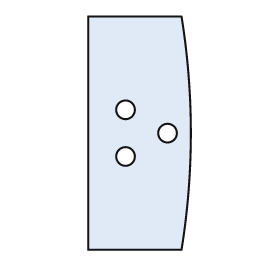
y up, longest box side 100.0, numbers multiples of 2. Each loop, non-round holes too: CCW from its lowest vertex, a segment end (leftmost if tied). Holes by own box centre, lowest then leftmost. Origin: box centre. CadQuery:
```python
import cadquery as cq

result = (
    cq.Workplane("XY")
    .moveTo(-22.0, -50.0)
    .lineTo(18.0, -50.0)
    .threePointArc((22.0, 0.0), (18.0, 50.0))
    .lineTo(-22.0, 50.0)
    .close()
    .moveTo(-6.0, -10.0)
    .circle(4.0)
    .moveTo(12.0, 0.0)
    .circle(4.0)
    .moveTo(-6.0, 10.0)
    .circle(4.0)
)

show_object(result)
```